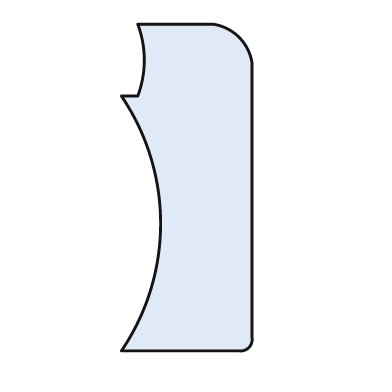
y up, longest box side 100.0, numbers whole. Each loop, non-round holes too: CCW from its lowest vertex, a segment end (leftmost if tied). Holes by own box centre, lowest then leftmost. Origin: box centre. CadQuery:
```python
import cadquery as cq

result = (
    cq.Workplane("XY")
    .moveTo(-20.0, -50.0)
    .lineTo(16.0, -50.0)
    .threePointArc((19.0, -49.0), (20.0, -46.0))
    .lineTo(20.0, 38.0)
    .threePointArc((16.0, 46.0), (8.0, 50.0))
    .lineTo(-15.0, 50.0)
    .threePointArc((-13.0, 39.0), (-15.0, 28.0))
    .lineTo(-20.0, 28.0)
    .threePointArc((-8.0, -11.0), (-20.0, -50.0))
    .close()
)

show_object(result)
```